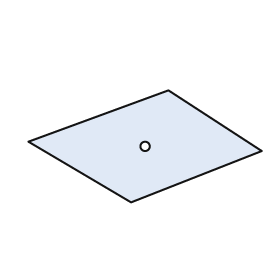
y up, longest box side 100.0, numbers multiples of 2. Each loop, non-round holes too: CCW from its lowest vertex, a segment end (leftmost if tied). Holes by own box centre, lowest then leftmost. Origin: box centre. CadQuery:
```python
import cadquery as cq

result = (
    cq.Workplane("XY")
    .moveTo(-6.0, -24.0)
    .lineTo(50.0, -2.0)
    .lineTo(10.0, 24.0)
    .lineTo(-50.0, 2.0)
    .close()
    .moveTo(0.0, 0.0)
    .circle(2.0)
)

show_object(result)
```